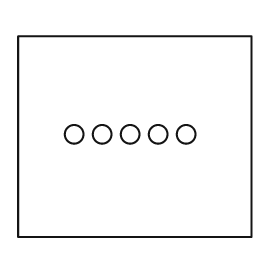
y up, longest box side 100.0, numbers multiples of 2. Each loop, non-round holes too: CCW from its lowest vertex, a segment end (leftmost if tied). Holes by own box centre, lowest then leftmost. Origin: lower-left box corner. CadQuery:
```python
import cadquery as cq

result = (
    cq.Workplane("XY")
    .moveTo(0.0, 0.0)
    .lineTo(100.0, 0.0)
    .lineTo(100.0, 86.0)
    .lineTo(0.0, 86.0)
    .close()
    .moveTo(24.0, 44.0)
    .circle(4.0)
    .moveTo(36.0, 44.0)
    .circle(4.0)
    .moveTo(48.0, 44.0)
    .circle(4.0)
    .moveTo(60.0, 44.0)
    .circle(4.0)
    .moveTo(72.0, 44.0)
    .circle(4.0)
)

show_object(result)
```